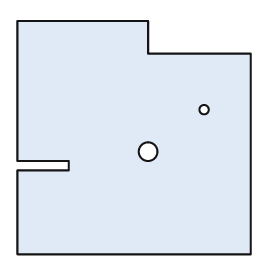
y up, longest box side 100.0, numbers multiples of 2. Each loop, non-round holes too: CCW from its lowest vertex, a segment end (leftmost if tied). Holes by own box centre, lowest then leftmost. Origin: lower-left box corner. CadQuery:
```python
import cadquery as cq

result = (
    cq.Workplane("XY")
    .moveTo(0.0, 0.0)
    .lineTo(100.0, 0.0)
    .lineTo(100.0, 86.0)
    .lineTo(56.0, 86.0)
    .lineTo(56.0, 100.0)
    .lineTo(0.0, 100.0)
    .lineTo(0.0, 40.0)
    .lineTo(22.0, 40.0)
    .lineTo(22.0, 36.0)
    .lineTo(0.0, 36.0)
    .close()
    .moveTo(56.0, 44.0)
    .circle(4.0)
    .moveTo(80.0, 62.0)
    .circle(2.0)
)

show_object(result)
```